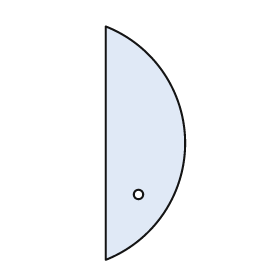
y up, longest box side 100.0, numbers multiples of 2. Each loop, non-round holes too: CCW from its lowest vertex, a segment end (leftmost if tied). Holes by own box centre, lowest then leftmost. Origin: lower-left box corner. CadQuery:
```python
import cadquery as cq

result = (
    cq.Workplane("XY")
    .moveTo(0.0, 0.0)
    .threePointArc((34.0, 50.0), (0.0, 100.0))
    .close()
    .moveTo(14.0, 28.0)
    .circle(2.0)
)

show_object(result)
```